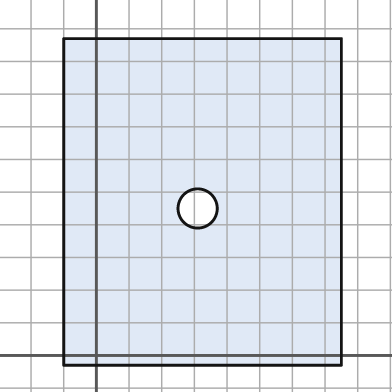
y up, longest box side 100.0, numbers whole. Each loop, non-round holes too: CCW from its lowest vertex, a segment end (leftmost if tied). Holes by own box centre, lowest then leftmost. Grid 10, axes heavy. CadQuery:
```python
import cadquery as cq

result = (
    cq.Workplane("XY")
    .moveTo(-10.0, -3.0)
    .lineTo(75.0, -3.0)
    .lineTo(75.0, 97.0)
    .lineTo(-10.0, 97.0)
    .close()
    .moveTo(31.0, 45.0)
    .circle(6.0)
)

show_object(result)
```